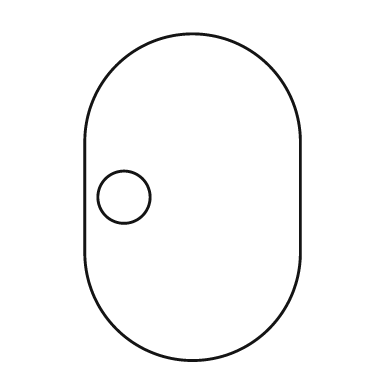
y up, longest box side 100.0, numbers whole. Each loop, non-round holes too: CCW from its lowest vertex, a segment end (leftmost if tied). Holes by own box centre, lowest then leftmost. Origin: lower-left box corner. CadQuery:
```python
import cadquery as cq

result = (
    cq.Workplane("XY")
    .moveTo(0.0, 33.0)
    .threePointArc((33.0, 0.0), (66.0, 33.0))
    .lineTo(66.0, 67.0)
    .threePointArc((33.0, 100.0), (0.0, 67.0))
    .close()
    .moveTo(12.0, 50.0)
    .circle(8.0)
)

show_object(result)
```